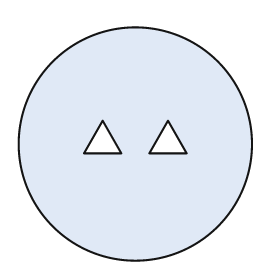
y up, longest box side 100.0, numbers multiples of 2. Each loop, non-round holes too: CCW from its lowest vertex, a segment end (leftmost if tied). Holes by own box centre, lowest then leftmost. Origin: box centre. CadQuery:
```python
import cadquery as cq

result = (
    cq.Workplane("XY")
    .moveTo(0.0, 0.0)
    .circle(50.0)
    .moveTo(-22.0, -4.0)
    .lineTo(-6.0, -4.0)
    .lineTo(-14.0, 10.0)
    .close()
    .moveTo(6.0, -4.0)
    .lineTo(22.0, -4.0)
    .lineTo(14.0, 10.0)
    .close()
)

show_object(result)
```